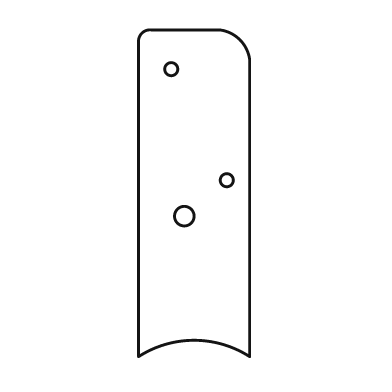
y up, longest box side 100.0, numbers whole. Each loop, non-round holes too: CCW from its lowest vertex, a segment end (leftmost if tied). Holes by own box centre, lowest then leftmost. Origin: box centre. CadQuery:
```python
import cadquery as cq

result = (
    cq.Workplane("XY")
    .moveTo(-17.0, -50.0)
    .threePointArc((0.0, -45.0), (17.0, -50.0))
    .lineTo(17.0, 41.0)
    .threePointArc((14.0, 47.0), (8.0, 50.0))
    .lineTo(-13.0, 50.0)
    .threePointArc((-16.0, 49.0), (-17.0, 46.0))
    .close()
    .moveTo(-3.0, -7.0)
    .circle(3.0)
    .moveTo(10.0, 4.0)
    .circle(2.0)
    .moveTo(-7.0, 38.0)
    .circle(2.0)
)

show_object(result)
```